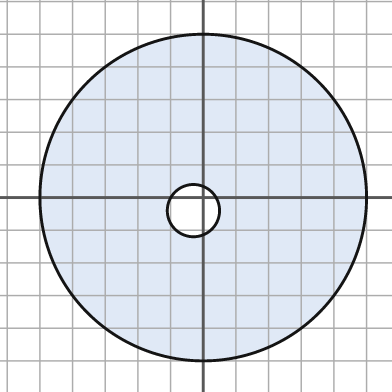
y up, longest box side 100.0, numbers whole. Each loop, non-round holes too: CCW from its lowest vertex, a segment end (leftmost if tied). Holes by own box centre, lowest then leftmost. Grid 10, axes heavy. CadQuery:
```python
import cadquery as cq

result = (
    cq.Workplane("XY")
    .moveTo(0.0, 0.0)
    .circle(50.0)
    .moveTo(-3.0, -4.0)
    .circle(8.0)
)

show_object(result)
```